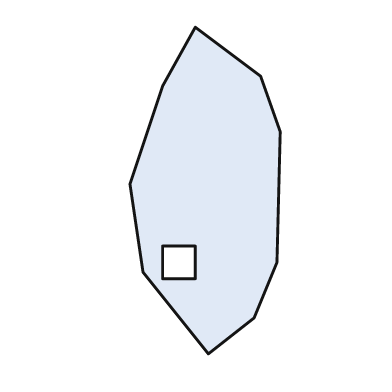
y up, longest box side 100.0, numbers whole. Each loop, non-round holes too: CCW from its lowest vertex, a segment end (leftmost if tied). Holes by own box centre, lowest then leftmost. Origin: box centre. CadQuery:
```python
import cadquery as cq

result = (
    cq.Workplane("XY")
    .moveTo(1.0, -50.0)
    .lineTo(15.0, -39.0)
    .lineTo(22.0, -22.0)
    .lineTo(23.0, 18.0)
    .lineTo(17.0, 35.0)
    .lineTo(-3.0, 50.0)
    .lineTo(-13.0, 32.0)
    .lineTo(-23.0, 2.0)
    .lineTo(-19.0, -25.0)
    .close()
    .moveTo(-13.0, -27.0)
    .lineTo(-3.0, -27.0)
    .lineTo(-3.0, -17.0)
    .lineTo(-13.0, -17.0)
    .close()
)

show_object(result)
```